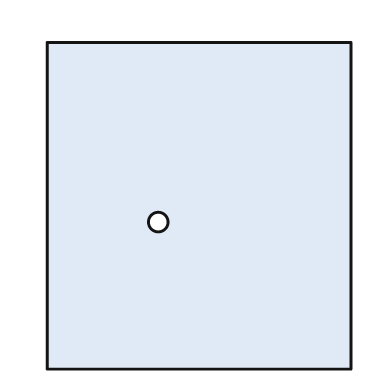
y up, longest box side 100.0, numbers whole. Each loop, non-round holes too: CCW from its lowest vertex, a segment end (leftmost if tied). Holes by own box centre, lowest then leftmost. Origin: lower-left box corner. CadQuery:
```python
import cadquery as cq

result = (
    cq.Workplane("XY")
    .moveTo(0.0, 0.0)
    .lineTo(93.0, 0.0)
    .lineTo(93.0, 100.0)
    .lineTo(0.0, 100.0)
    .close()
    .moveTo(34.0, 45.0)
    .circle(3.0)
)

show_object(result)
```